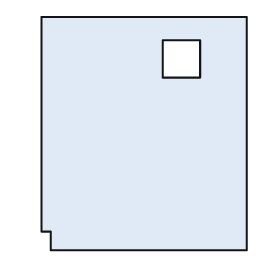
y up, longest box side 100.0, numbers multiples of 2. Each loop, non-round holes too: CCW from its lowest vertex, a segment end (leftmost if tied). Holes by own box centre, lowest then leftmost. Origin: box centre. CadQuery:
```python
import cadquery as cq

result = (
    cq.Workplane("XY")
    .moveTo(-40.0, -50.0)
    .lineTo(44.0, -50.0)
    .lineTo(44.0, 50.0)
    .lineTo(-44.0, 50.0)
    .lineTo(-44.0, -42.0)
    .lineTo(-40.0, -42.0)
    .close()
    .moveTo(8.0, 24.0)
    .lineTo(24.0, 24.0)
    .lineTo(24.0, 40.0)
    .lineTo(8.0, 40.0)
    .close()
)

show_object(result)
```